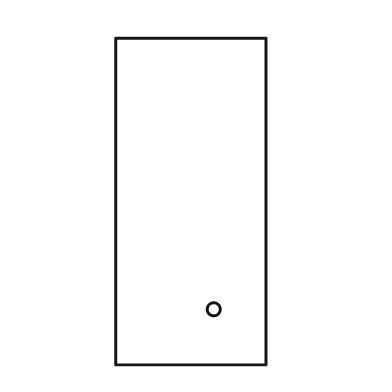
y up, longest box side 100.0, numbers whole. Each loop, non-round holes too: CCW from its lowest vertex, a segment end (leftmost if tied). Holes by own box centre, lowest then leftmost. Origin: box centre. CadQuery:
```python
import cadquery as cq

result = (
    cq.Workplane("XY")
    .moveTo(-23.0, -50.0)
    .lineTo(23.0, -50.0)
    .lineTo(23.0, 50.0)
    .lineTo(-23.0, 50.0)
    .close()
    .moveTo(7.0, -33.0)
    .circle(2.0)
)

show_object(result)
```